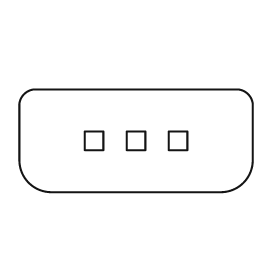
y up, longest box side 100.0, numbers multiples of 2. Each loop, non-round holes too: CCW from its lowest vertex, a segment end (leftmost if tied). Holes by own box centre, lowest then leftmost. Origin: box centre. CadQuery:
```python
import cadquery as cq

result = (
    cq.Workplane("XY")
    .moveTo(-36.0, -22.0)
    .lineTo(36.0, -22.0)
    .threePointArc((46.0, -18.0), (50.0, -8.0))
    .lineTo(50.0, 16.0)
    .threePointArc((48.0, 20.0), (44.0, 22.0))
    .lineTo(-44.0, 22.0)
    .threePointArc((-48.0, 20.0), (-50.0, 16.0))
    .lineTo(-50.0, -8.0)
    .threePointArc((-46.0, -18.0), (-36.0, -22.0))
    .close()
    .moveTo(-22.0, -4.0)
    .lineTo(-14.0, -4.0)
    .lineTo(-14.0, 4.0)
    .lineTo(-22.0, 4.0)
    .close()
    .moveTo(-4.0, -4.0)
    .lineTo(4.0, -4.0)
    .lineTo(4.0, 4.0)
    .lineTo(-4.0, 4.0)
    .close()
    .moveTo(14.0, -4.0)
    .lineTo(22.0, -4.0)
    .lineTo(22.0, 4.0)
    .lineTo(14.0, 4.0)
    .close()
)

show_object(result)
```